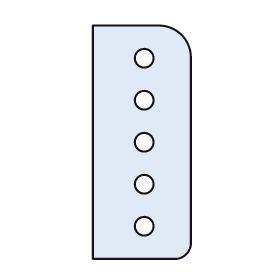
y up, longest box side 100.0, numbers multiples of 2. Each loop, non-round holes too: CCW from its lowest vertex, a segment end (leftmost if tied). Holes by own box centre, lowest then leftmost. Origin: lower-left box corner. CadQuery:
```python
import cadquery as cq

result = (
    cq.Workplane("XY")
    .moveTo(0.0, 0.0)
    .lineTo(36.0, 0.0)
    .threePointArc((40.0, 2.0), (42.0, 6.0))
    .lineTo(42.0, 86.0)
    .threePointArc((38.0, 96.0), (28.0, 100.0))
    .lineTo(0.0, 100.0)
    .close()
    .moveTo(22.0, 14.0)
    .circle(4.0)
    .moveTo(22.0, 32.0)
    .circle(4.0)
    .moveTo(22.0, 50.0)
    .circle(4.0)
    .moveTo(22.0, 68.0)
    .circle(4.0)
    .moveTo(22.0, 86.0)
    .circle(4.0)
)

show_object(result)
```